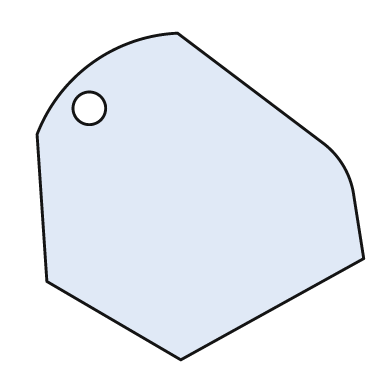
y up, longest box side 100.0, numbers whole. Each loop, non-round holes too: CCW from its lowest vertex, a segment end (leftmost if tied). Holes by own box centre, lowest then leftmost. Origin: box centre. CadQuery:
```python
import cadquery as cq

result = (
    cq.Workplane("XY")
    .moveTo(-6.0, -50.0)
    .lineTo(50.0, -19.0)
    .lineTo(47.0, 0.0)
    .threePointArc((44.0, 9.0), (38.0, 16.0))
    .lineTo(-7.0, 50.0)
    .threePointArc((-33.0, 41.0), (-50.0, 19.0))
    .lineTo(-47.0, -26.0)
    .close()
    .moveTo(-34.0, 27.0)
    .circle(5.0)
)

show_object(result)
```